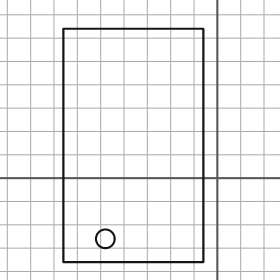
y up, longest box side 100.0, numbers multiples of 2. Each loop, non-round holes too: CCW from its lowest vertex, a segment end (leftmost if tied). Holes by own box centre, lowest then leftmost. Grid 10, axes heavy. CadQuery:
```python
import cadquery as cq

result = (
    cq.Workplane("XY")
    .moveTo(-66.0, -36.0)
    .lineTo(-6.0, -36.0)
    .lineTo(-6.0, 64.0)
    .lineTo(-66.0, 64.0)
    .close()
    .moveTo(-48.0, -26.0)
    .circle(4.0)
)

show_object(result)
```